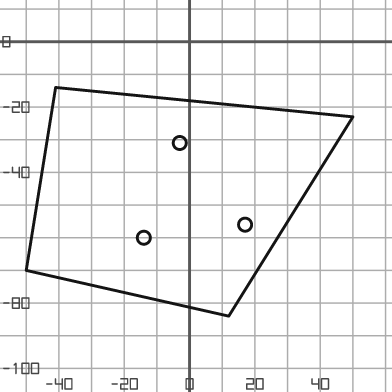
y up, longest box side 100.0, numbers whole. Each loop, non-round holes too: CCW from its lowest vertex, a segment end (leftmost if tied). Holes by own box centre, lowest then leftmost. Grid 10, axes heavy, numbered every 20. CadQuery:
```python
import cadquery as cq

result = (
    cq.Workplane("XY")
    .moveTo(12.0, -84.0)
    .lineTo(50.0, -23.0)
    .lineTo(-41.0, -14.0)
    .lineTo(-50.0, -70.0)
    .close()
    .moveTo(-14.0, -60.0)
    .circle(2.0)
    .moveTo(17.0, -56.0)
    .circle(2.0)
    .moveTo(-3.0, -31.0)
    .circle(2.0)
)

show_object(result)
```